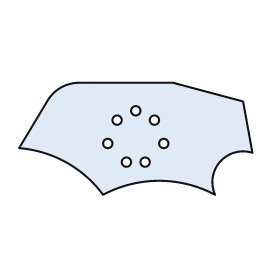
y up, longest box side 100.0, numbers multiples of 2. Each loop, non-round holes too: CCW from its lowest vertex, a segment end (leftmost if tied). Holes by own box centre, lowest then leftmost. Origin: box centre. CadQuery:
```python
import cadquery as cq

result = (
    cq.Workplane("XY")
    .moveTo(-14.0, -24.0)
    .threePointArc((10.0, -18.0), (34.0, -24.0))
    .threePointArc((36.0, -10.0), (50.0, -6.0))
    .lineTo(46.0, 16.0)
    .lineTo(16.0, 24.0)
    .lineTo(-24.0, 24.0)
    .threePointArc((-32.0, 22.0), (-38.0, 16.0))
    .lineTo(-50.0, -4.0)
    .threePointArc((-30.0, -10.0), (-14.0, -24.0))
    .close()
    .moveTo(-4.0, -10.0)
    .circle(2.0)
    .moveTo(4.0, -10.0)
    .circle(2.0)
    .moveTo(-12.0, -2.0)
    .circle(2.0)
    .moveTo(12.0, -2.0)
    .circle(2.0)
    .moveTo(-8.0, 8.0)
    .circle(2.0)
    .moveTo(8.0, 8.0)
    .circle(2.0)
    .moveTo(0.0, 12.0)
    .circle(2.0)
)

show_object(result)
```